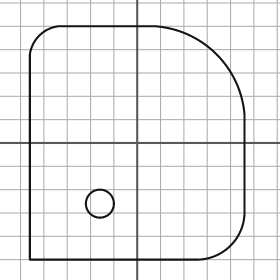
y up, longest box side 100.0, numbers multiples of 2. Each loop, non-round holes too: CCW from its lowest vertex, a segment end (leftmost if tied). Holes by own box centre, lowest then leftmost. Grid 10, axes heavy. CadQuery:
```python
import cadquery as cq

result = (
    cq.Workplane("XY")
    .moveTo(-46.0, -50.0)
    .lineTo(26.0, -50.0)
    .threePointArc((40.0, -44.0), (46.0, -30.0))
    .lineTo(46.0, 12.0)
    .threePointArc((34.0, 38.0), (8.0, 50.0))
    .lineTo(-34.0, 50.0)
    .threePointArc((-42.0, 46.0), (-46.0, 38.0))
    .close()
    .moveTo(-16.0, -26.0)
    .circle(6.0)
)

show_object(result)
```